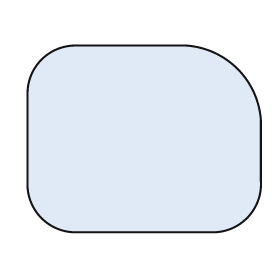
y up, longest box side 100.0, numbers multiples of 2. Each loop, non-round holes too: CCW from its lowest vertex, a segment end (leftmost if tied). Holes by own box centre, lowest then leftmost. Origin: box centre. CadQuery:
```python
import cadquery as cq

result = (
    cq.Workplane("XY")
    .moveTo(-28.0, -40.0)
    .lineTo(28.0, -40.0)
    .threePointArc((44.0, -34.0), (50.0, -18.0))
    .lineTo(50.0, 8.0)
    .threePointArc((40.0, 30.0), (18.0, 40.0))
    .lineTo(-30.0, 40.0)
    .threePointArc((-44.0, 34.0), (-50.0, 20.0))
    .lineTo(-50.0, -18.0)
    .threePointArc((-44.0, -34.0), (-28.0, -40.0))
    .close()
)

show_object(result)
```